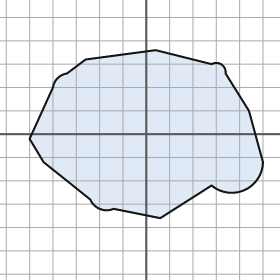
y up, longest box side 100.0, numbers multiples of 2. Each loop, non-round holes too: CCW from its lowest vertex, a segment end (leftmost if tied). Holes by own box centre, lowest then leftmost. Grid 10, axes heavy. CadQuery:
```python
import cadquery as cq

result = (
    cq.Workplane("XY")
    .moveTo(6.0, -36.0)
    .lineTo(28.0, -22.0)
    .threePointArc((42.0, -24.0), (50.0, -12.0))
    .lineTo(44.0, 10.0)
    .lineTo(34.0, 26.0)
    .threePointArc((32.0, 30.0), (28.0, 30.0))
    .lineTo(4.0, 36.0)
    .lineTo(-26.0, 32.0)
    .lineTo(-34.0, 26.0)
    .threePointArc((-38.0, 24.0), (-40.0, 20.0))
    .lineTo(-50.0, -2.0)
    .lineTo(-44.0, -12.0)
    .lineTo(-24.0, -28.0)
    .threePointArc((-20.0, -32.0), (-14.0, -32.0))
    .close()
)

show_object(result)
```